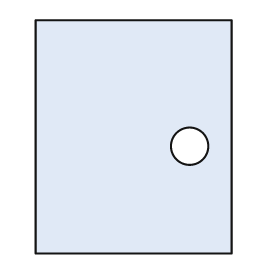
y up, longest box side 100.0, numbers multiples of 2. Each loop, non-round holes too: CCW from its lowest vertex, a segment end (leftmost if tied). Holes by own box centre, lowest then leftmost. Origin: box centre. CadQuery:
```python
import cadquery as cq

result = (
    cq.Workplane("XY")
    .moveTo(-42.0, -50.0)
    .lineTo(42.0, -50.0)
    .lineTo(42.0, 50.0)
    .lineTo(-42.0, 50.0)
    .close()
    .moveTo(24.0, -4.0)
    .circle(8.0)
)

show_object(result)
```